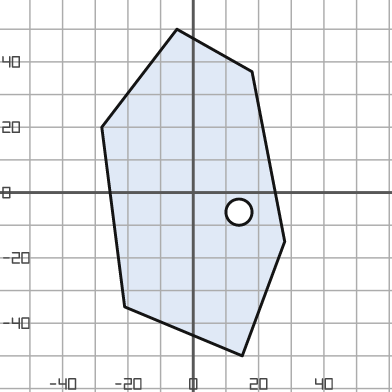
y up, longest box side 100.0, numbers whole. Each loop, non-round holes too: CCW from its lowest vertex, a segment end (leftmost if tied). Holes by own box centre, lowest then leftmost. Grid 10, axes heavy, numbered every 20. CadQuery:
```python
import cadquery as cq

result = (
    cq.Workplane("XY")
    .moveTo(15.0, -50.0)
    .lineTo(28.0, -15.0)
    .lineTo(18.0, 37.0)
    .lineTo(-5.0, 50.0)
    .lineTo(-28.0, 20.0)
    .lineTo(-21.0, -35.0)
    .close()
    .moveTo(14.0, -6.0)
    .circle(4.0)
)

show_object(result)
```